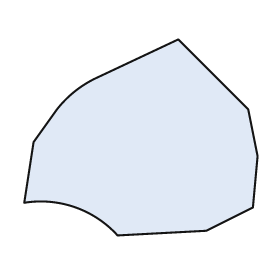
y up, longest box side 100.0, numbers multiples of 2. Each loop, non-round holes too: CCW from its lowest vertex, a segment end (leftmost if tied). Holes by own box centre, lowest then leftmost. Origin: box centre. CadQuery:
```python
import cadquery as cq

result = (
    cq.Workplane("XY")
    .moveTo(-10.0, -42.0)
    .lineTo(28.0, -40.0)
    .lineTo(48.0, -30.0)
    .lineTo(50.0, -8.0)
    .lineTo(46.0, 12.0)
    .lineTo(16.0, 42.0)
    .lineTo(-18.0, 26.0)
    .threePointArc((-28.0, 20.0), (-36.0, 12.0))
    .lineTo(-46.0, -2.0)
    .lineTo(-50.0, -28.0)
    .threePointArc((-28.0, -30.0), (-10.0, -42.0))
    .close()
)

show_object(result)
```